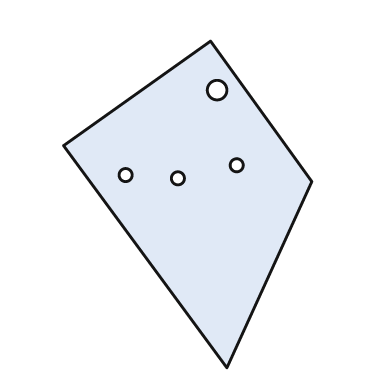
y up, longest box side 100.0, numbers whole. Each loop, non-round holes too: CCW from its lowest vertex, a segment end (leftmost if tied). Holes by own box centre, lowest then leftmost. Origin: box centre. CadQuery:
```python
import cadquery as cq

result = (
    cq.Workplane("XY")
    .moveTo(12.0, -50.0)
    .lineTo(38.0, 7.0)
    .lineTo(7.0, 50.0)
    .lineTo(-38.0, 18.0)
    .close()
    .moveTo(-3.0, 8.0)
    .circle(2.0)
    .moveTo(-19.0, 9.0)
    .circle(2.0)
    .moveTo(15.0, 12.0)
    .circle(2.0)
    .moveTo(9.0, 35.0)
    .circle(3.0)
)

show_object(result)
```